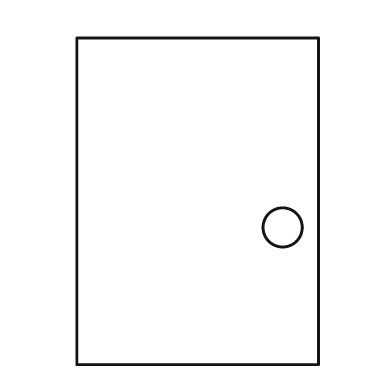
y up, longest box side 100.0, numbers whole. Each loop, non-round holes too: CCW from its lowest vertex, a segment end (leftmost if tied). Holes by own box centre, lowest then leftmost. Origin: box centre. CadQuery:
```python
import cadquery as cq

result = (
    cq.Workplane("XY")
    .moveTo(-37.0, -50.0)
    .lineTo(37.0, -50.0)
    .lineTo(37.0, 50.0)
    .lineTo(-37.0, 50.0)
    .close()
    .moveTo(26.0, -8.0)
    .circle(6.0)
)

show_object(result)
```